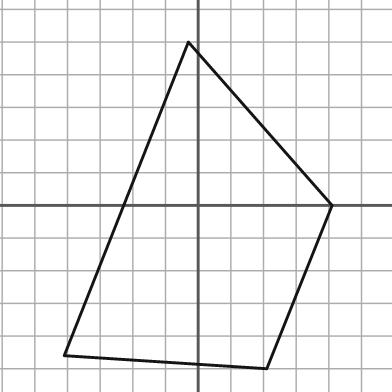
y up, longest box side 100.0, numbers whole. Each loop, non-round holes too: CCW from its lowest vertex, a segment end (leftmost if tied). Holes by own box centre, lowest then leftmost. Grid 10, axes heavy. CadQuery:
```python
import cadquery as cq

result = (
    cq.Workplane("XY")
    .moveTo(21.0, -50.0)
    .lineTo(41.0, 0.0)
    .lineTo(-3.0, 50.0)
    .lineTo(-41.0, -46.0)
    .close()
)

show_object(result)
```